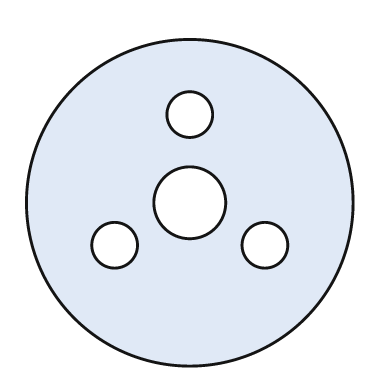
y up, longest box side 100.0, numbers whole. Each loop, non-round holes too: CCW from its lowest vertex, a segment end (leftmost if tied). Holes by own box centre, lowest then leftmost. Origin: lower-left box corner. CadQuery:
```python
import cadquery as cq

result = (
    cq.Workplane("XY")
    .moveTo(50.0, 50.0)
    .circle(50.0)
    .moveTo(27.0, 37.0)
    .circle(7.0)
    .moveTo(73.0, 37.0)
    .circle(7.0)
    .moveTo(50.0, 50.0)
    .circle(11.0)
    .moveTo(50.0, 77.0)
    .circle(7.0)
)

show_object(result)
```